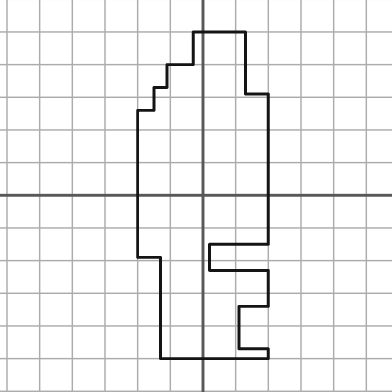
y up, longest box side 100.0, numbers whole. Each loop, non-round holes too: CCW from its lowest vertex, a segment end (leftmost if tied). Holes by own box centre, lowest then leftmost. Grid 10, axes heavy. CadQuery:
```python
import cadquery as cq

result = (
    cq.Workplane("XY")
    .moveTo(-13.0, -50.0)
    .lineTo(20.0, -50.0)
    .lineTo(20.0, -47.0)
    .lineTo(11.0, -47.0)
    .lineTo(11.0, -34.0)
    .lineTo(20.0, -34.0)
    .lineTo(20.0, -23.0)
    .lineTo(2.0, -23.0)
    .lineTo(2.0, -15.0)
    .lineTo(20.0, -15.0)
    .lineTo(20.0, 31.0)
    .lineTo(13.0, 31.0)
    .lineTo(13.0, 50.0)
    .lineTo(-3.0, 50.0)
    .lineTo(-3.0, 40.0)
    .lineTo(-11.0, 40.0)
    .lineTo(-11.0, 33.0)
    .lineTo(-15.0, 33.0)
    .lineTo(-15.0, 26.0)
    .lineTo(-20.0, 26.0)
    .lineTo(-20.0, -19.0)
    .lineTo(-13.0, -19.0)
    .close()
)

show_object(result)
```